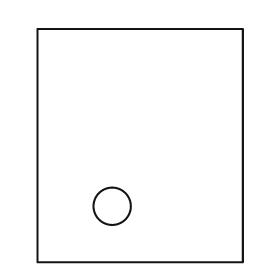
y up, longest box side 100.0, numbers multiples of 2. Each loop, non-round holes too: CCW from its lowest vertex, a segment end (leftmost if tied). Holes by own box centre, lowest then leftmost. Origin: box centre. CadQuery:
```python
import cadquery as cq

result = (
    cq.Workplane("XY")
    .moveTo(-44.0, -50.0)
    .lineTo(44.0, -50.0)
    .lineTo(44.0, 50.0)
    .lineTo(-44.0, 50.0)
    .close()
    .moveTo(-12.0, -26.0)
    .circle(8.0)
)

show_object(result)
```